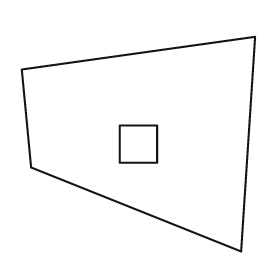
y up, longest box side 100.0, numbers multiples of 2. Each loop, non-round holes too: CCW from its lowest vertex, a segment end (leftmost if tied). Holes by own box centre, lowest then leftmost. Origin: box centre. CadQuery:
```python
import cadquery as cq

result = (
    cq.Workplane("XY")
    .moveTo(44.0, -46.0)
    .lineTo(50.0, 46.0)
    .lineTo(-50.0, 32.0)
    .lineTo(-46.0, -10.0)
    .close()
    .moveTo(-8.0, -8.0)
    .lineTo(8.0, -8.0)
    .lineTo(8.0, 8.0)
    .lineTo(-8.0, 8.0)
    .close()
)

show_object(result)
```